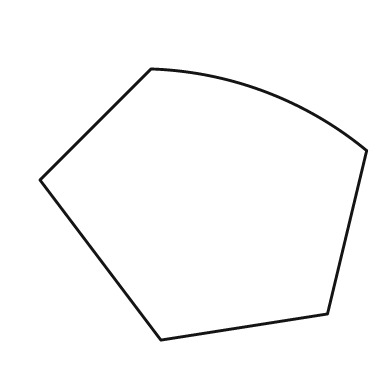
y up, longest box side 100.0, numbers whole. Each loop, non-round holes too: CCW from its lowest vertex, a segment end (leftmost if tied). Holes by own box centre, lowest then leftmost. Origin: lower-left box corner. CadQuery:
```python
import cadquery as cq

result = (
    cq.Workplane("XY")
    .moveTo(37.0, 0.0)
    .lineTo(88.0, 8.0)
    .lineTo(100.0, 58.0)
    .threePointArc((69.0, 76.0), (34.0, 83.0))
    .lineTo(0.0, 49.0)
    .close()
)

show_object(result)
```